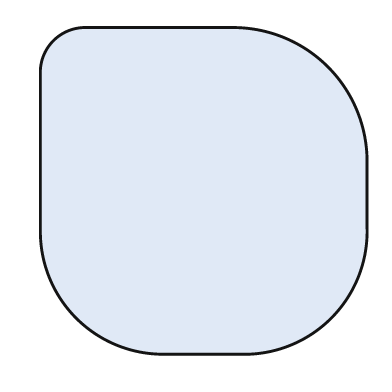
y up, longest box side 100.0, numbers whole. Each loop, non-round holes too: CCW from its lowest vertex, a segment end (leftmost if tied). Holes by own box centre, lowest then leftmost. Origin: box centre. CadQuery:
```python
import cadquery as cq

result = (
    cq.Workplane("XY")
    .moveTo(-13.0, -50.0)
    .lineTo(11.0, -50.0)
    .threePointArc((39.0, -39.0), (50.0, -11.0))
    .lineTo(50.0, 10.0)
    .threePointArc((38.0, 38.0), (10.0, 50.0))
    .lineTo(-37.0, 50.0)
    .threePointArc((-46.0, 46.0), (-50.0, 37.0))
    .lineTo(-50.0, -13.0)
    .threePointArc((-39.0, -39.0), (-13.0, -50.0))
    .close()
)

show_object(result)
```